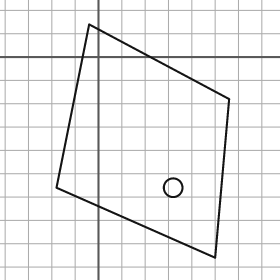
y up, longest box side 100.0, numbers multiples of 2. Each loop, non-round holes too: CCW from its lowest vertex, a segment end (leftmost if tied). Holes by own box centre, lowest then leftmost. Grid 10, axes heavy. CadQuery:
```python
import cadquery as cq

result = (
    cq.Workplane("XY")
    .moveTo(50.0, -86.0)
    .lineTo(56.0, -18.0)
    .lineTo(-4.0, 14.0)
    .lineTo(-18.0, -56.0)
    .close()
    .moveTo(32.0, -56.0)
    .circle(4.0)
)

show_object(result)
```